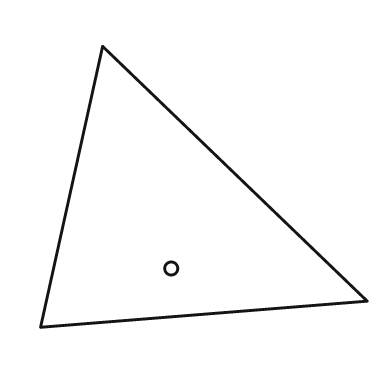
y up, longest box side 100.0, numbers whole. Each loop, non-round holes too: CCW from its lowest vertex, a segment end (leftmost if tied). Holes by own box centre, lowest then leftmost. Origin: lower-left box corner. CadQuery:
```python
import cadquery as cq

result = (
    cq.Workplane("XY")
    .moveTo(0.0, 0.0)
    .lineTo(100.0, 8.0)
    .lineTo(19.0, 86.0)
    .close()
    .moveTo(40.0, 18.0)
    .circle(2.0)
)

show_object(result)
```